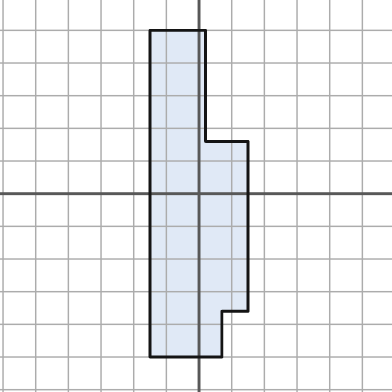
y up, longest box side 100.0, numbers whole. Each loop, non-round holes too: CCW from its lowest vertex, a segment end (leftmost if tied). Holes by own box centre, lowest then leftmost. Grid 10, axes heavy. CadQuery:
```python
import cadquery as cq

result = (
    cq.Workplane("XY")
    .moveTo(-15.0, -50.0)
    .lineTo(7.0, -50.0)
    .lineTo(7.0, -36.0)
    .lineTo(15.0, -36.0)
    .lineTo(15.0, 16.0)
    .lineTo(2.0, 16.0)
    .lineTo(2.0, 50.0)
    .lineTo(-15.0, 50.0)
    .close()
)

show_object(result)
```